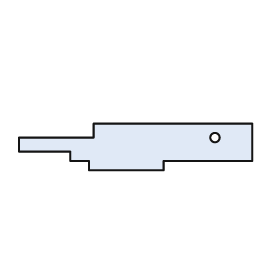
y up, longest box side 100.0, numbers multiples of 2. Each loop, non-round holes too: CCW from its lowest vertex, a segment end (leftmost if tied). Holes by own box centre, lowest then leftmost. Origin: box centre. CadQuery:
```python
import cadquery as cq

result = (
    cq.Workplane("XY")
    .moveTo(-20.0, -10.0)
    .lineTo(12.0, -10.0)
    .lineTo(12.0, -6.0)
    .lineTo(50.0, -6.0)
    .lineTo(50.0, 10.0)
    .lineTo(-18.0, 10.0)
    .lineTo(-18.0, 4.0)
    .lineTo(-50.0, 4.0)
    .lineTo(-50.0, -2.0)
    .lineTo(-28.0, -2.0)
    .lineTo(-28.0, -6.0)
    .lineTo(-20.0, -6.0)
    .close()
    .moveTo(34.0, 4.0)
    .circle(2.0)
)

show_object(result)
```